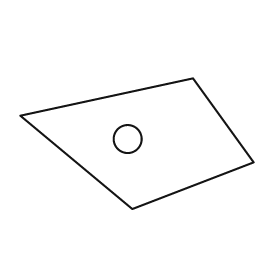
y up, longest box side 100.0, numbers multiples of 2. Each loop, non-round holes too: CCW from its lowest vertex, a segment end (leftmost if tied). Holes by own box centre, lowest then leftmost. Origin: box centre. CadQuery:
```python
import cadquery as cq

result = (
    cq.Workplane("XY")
    .moveTo(-2.0, -28.0)
    .lineTo(50.0, -8.0)
    .lineTo(24.0, 28.0)
    .lineTo(-50.0, 12.0)
    .close()
    .moveTo(-4.0, 2.0)
    .circle(6.0)
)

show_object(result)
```